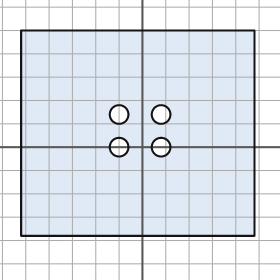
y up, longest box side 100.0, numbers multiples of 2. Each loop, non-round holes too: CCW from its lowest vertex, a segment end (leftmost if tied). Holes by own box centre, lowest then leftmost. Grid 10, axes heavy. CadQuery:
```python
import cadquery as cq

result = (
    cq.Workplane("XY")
    .moveTo(-52.0, -38.0)
    .lineTo(48.0, -38.0)
    .lineTo(48.0, 50.0)
    .lineTo(-52.0, 50.0)
    .close()
    .moveTo(-10.0, 0.0)
    .circle(4.0)
    .moveTo(8.0, 0.0)
    .circle(4.0)
    .moveTo(-10.0, 14.0)
    .circle(4.0)
    .moveTo(8.0, 14.0)
    .circle(4.0)
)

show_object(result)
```